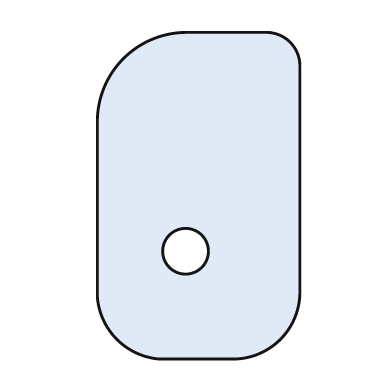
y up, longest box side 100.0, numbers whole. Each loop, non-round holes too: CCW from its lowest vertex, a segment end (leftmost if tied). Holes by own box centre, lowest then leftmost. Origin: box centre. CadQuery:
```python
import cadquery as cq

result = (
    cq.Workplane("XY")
    .moveTo(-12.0, -50.0)
    .lineTo(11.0, -50.0)
    .threePointArc((25.0, -44.0), (31.0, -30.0))
    .lineTo(31.0, 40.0)
    .threePointArc((28.0, 47.0), (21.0, 50.0))
    .lineTo(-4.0, 50.0)
    .threePointArc((-23.0, 42.0), (-31.0, 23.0))
    .lineTo(-31.0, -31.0)
    .threePointArc((-25.0, -44.0), (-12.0, -50.0))
    .close()
    .moveTo(-4.0, -17.0)
    .circle(7.0)
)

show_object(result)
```